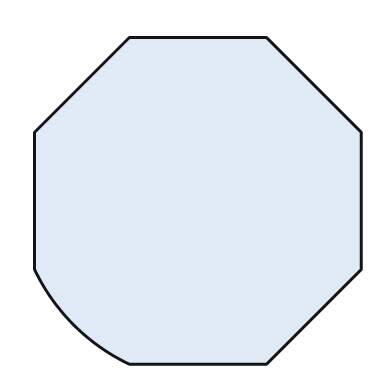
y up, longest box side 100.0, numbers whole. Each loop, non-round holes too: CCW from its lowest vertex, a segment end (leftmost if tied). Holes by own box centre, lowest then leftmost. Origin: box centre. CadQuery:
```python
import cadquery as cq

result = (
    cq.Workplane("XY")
    .moveTo(-21.0, -50.0)
    .lineTo(21.0, -50.0)
    .lineTo(50.0, -21.0)
    .lineTo(50.0, 21.0)
    .lineTo(21.0, 50.0)
    .lineTo(-21.0, 50.0)
    .lineTo(-50.0, 21.0)
    .lineTo(-50.0, -21.0)
    .threePointArc((-38.0, -38.0), (-21.0, -50.0))
    .close()
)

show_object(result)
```